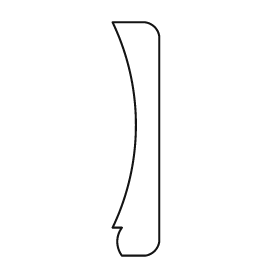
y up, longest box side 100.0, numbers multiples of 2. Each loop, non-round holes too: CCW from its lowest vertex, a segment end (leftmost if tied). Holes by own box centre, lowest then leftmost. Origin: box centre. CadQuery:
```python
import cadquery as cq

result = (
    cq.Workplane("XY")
    .moveTo(-6.0, -50.0)
    .lineTo(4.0, -50.0)
    .threePointArc((8.0, -48.0), (10.0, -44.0))
    .lineTo(10.0, 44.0)
    .threePointArc((8.0, 48.0), (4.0, 50.0))
    .lineTo(-10.0, 50.0)
    .threePointArc((0.0, 6.0), (-10.0, -38.0))
    .lineTo(-6.0, -38.0)
    .threePointArc((-8.0, -44.0), (-6.0, -50.0))
    .close()
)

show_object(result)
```